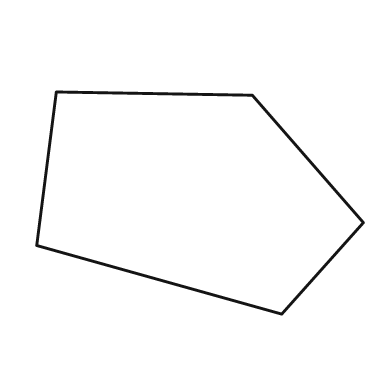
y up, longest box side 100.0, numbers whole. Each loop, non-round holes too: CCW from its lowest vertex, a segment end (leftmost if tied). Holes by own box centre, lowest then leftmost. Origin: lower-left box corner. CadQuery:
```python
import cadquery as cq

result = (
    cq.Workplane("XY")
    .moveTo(75.0, 0.0)
    .lineTo(100.0, 28.0)
    .lineTo(66.0, 67.0)
    .lineTo(6.0, 68.0)
    .lineTo(0.0, 21.0)
    .close()
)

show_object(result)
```